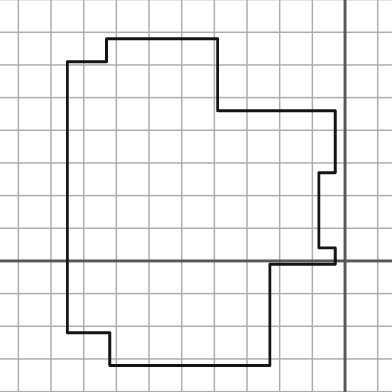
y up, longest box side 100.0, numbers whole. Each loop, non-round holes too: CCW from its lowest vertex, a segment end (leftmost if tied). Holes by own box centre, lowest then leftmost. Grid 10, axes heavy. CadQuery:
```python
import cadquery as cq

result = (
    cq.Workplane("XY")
    .moveTo(-72.0, -32.0)
    .lineTo(-23.0, -32.0)
    .lineTo(-23.0, -1.0)
    .lineTo(-3.0, -1.0)
    .lineTo(-3.0, 4.0)
    .lineTo(-8.0, 4.0)
    .lineTo(-8.0, 27.0)
    .lineTo(-3.0, 27.0)
    .lineTo(-3.0, 46.0)
    .lineTo(-39.0, 46.0)
    .lineTo(-39.0, 68.0)
    .lineTo(-73.0, 68.0)
    .lineTo(-73.0, 61.0)
    .lineTo(-85.0, 61.0)
    .lineTo(-85.0, -22.0)
    .lineTo(-72.0, -22.0)
    .close()
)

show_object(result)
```